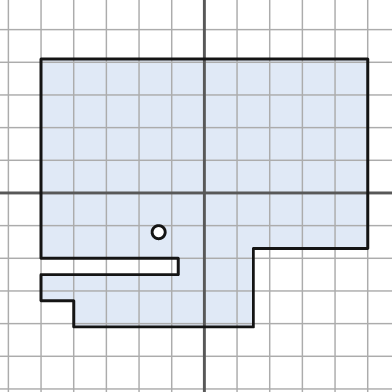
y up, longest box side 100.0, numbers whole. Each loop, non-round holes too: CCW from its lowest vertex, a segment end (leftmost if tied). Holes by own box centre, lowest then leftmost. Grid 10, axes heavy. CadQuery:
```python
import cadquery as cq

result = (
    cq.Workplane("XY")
    .moveTo(-40.0, -41.0)
    .lineTo(15.0, -41.0)
    .lineTo(15.0, -17.0)
    .lineTo(50.0, -17.0)
    .lineTo(50.0, 41.0)
    .lineTo(-50.0, 41.0)
    .lineTo(-50.0, -20.0)
    .lineTo(-8.0, -20.0)
    .lineTo(-8.0, -25.0)
    .lineTo(-50.0, -25.0)
    .lineTo(-50.0, -33.0)
    .lineTo(-40.0, -33.0)
    .close()
    .moveTo(-14.0, -12.0)
    .circle(2.0)
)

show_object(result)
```